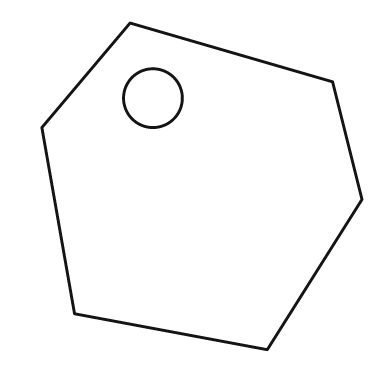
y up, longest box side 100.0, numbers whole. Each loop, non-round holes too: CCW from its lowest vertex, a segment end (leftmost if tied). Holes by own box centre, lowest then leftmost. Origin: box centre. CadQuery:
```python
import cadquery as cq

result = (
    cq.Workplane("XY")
    .moveTo(20.0, -50.0)
    .lineTo(49.0, -4.0)
    .lineTo(40.0, 32.0)
    .lineTo(-22.0, 50.0)
    .lineTo(-49.0, 18.0)
    .lineTo(-39.0, -39.0)
    .close()
    .moveTo(-15.0, 27.0)
    .circle(9.0)
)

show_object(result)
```